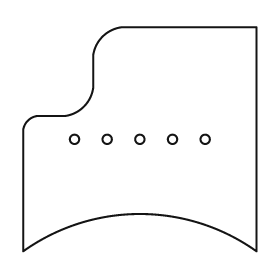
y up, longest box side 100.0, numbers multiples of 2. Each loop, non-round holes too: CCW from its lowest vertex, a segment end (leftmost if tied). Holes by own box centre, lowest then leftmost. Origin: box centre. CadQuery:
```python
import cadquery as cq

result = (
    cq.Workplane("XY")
    .moveTo(-50.0, -48.0)
    .threePointArc((0.0, -32.0), (50.0, -48.0))
    .lineTo(50.0, 48.0)
    .lineTo(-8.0, 48.0)
    .threePointArc((-16.0, 44.0), (-20.0, 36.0))
    .lineTo(-20.0, 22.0)
    .threePointArc((-24.0, 14.0), (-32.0, 10.0))
    .lineTo(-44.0, 10.0)
    .threePointArc((-48.0, 8.0), (-50.0, 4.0))
    .close()
    .moveTo(-28.0, 0.0)
    .circle(2.0)
    .moveTo(-14.0, 0.0)
    .circle(2.0)
    .moveTo(0.0, 0.0)
    .circle(2.0)
    .moveTo(14.0, 0.0)
    .circle(2.0)
    .moveTo(28.0, 0.0)
    .circle(2.0)
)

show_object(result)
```